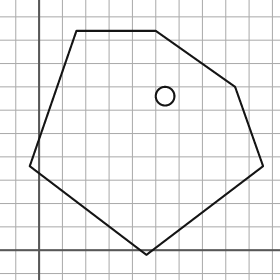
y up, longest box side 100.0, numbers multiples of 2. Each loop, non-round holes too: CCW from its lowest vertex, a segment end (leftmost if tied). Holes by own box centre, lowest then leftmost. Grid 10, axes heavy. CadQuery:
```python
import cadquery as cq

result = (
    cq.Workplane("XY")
    .moveTo(46.0, -2.0)
    .lineTo(96.0, 36.0)
    .lineTo(84.0, 70.0)
    .lineTo(50.0, 94.0)
    .lineTo(16.0, 94.0)
    .lineTo(-4.0, 36.0)
    .close()
    .moveTo(54.0, 66.0)
    .circle(4.0)
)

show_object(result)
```